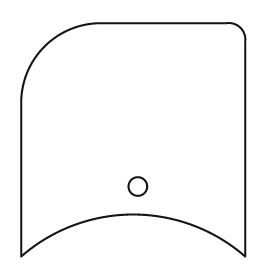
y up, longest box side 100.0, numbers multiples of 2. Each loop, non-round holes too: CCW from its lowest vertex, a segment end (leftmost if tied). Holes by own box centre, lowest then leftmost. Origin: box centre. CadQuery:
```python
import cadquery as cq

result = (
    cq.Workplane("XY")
    .moveTo(-48.0, -50.0)
    .threePointArc((0.0, -32.0), (48.0, -50.0))
    .lineTo(48.0, 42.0)
    .threePointArc((46.0, 48.0), (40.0, 50.0))
    .lineTo(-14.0, 50.0)
    .threePointArc((-38.0, 40.0), (-48.0, 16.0))
    .close()
    .moveTo(2.0, -20.0)
    .circle(4.0)
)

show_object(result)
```